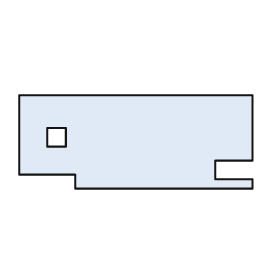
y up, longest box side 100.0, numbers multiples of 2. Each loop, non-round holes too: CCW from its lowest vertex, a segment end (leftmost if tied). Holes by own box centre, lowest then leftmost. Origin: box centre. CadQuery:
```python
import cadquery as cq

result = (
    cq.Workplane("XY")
    .moveTo(-26.0, -20.0)
    .lineTo(50.0, -20.0)
    .lineTo(50.0, -16.0)
    .lineTo(34.0, -16.0)
    .lineTo(34.0, -8.0)
    .lineTo(50.0, -8.0)
    .lineTo(50.0, 20.0)
    .lineTo(-50.0, 20.0)
    .lineTo(-50.0, -14.0)
    .lineTo(-26.0, -14.0)
    .close()
    .moveTo(-38.0, -2.0)
    .lineTo(-30.0, -2.0)
    .lineTo(-30.0, 6.0)
    .lineTo(-38.0, 6.0)
    .close()
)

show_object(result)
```